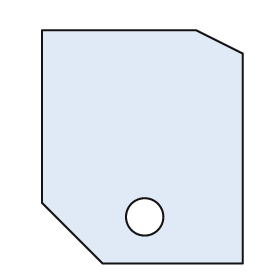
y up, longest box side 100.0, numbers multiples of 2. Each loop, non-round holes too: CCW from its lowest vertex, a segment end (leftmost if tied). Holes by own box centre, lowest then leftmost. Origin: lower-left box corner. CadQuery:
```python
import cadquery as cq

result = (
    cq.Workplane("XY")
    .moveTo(26.0, 0.0)
    .lineTo(86.0, 0.0)
    .lineTo(86.0, 90.0)
    .lineTo(66.0, 100.0)
    .lineTo(0.0, 100.0)
    .lineTo(0.0, 26.0)
    .close()
    .moveTo(44.0, 20.0)
    .circle(8.0)
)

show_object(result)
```